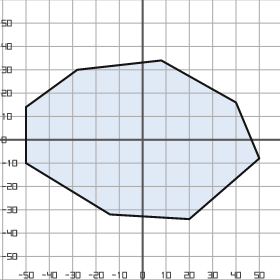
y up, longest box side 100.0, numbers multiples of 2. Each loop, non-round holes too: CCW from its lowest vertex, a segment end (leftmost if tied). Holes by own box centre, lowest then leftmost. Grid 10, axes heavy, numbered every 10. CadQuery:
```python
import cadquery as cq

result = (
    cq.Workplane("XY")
    .moveTo(20.0, -34.0)
    .lineTo(50.0, -8.0)
    .lineTo(40.0, 16.0)
    .lineTo(8.0, 34.0)
    .lineTo(-28.0, 30.0)
    .lineTo(-50.0, 14.0)
    .lineTo(-50.0, -10.0)
    .lineTo(-14.0, -32.0)
    .close()
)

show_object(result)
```